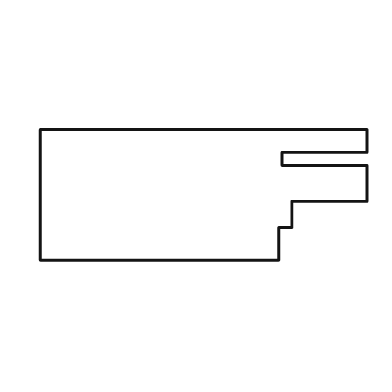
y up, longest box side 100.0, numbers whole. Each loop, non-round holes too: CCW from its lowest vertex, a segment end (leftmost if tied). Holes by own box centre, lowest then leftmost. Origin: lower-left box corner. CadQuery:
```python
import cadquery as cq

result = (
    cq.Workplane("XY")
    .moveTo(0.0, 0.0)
    .lineTo(73.0, 0.0)
    .lineTo(73.0, 10.0)
    .lineTo(77.0, 10.0)
    .lineTo(77.0, 18.0)
    .lineTo(100.0, 18.0)
    .lineTo(100.0, 29.0)
    .lineTo(74.0, 29.0)
    .lineTo(74.0, 33.0)
    .lineTo(100.0, 33.0)
    .lineTo(100.0, 40.0)
    .lineTo(0.0, 40.0)
    .close()
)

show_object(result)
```